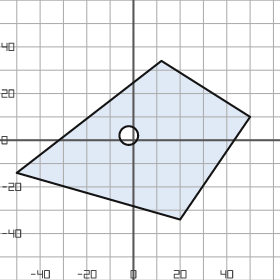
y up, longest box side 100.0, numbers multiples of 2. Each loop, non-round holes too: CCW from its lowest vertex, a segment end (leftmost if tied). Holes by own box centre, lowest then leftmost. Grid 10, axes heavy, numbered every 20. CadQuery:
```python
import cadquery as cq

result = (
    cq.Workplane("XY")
    .moveTo(20.0, -34.0)
    .lineTo(50.0, 10.0)
    .lineTo(12.0, 34.0)
    .lineTo(-50.0, -14.0)
    .close()
    .moveTo(-2.0, 2.0)
    .circle(4.0)
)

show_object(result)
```